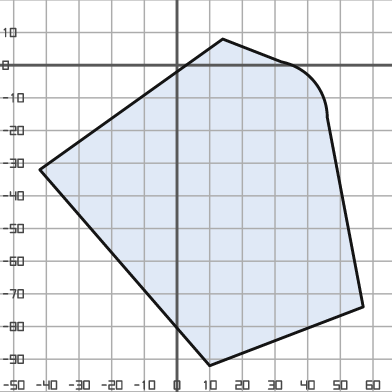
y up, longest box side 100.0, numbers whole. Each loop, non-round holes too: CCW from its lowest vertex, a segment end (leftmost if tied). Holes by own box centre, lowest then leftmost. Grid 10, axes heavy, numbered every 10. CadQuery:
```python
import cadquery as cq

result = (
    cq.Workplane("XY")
    .moveTo(10.0, -92.0)
    .lineTo(57.0, -74.0)
    .lineTo(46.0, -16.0)
    .threePointArc((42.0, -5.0), (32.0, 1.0))
    .lineTo(14.0, 8.0)
    .lineTo(-42.0, -32.0)
    .close()
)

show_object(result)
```